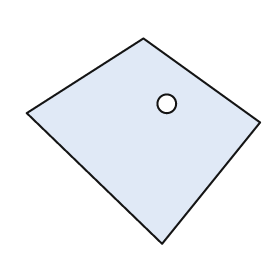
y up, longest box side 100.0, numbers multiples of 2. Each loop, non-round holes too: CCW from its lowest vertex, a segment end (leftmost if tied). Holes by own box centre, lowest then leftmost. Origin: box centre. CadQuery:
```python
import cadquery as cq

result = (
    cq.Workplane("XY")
    .moveTo(8.0, -44.0)
    .lineTo(50.0, 8.0)
    .lineTo(0.0, 44.0)
    .lineTo(-50.0, 12.0)
    .close()
    .moveTo(10.0, 16.0)
    .circle(4.0)
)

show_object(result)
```